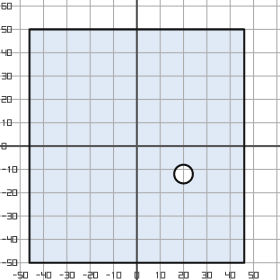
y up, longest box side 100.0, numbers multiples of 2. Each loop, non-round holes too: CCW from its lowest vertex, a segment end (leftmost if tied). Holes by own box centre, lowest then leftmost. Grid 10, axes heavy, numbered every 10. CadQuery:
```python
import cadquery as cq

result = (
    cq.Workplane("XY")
    .moveTo(-46.0, -50.0)
    .lineTo(46.0, -50.0)
    .lineTo(46.0, 50.0)
    .lineTo(-46.0, 50.0)
    .close()
    .moveTo(20.0, -12.0)
    .circle(4.0)
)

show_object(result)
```